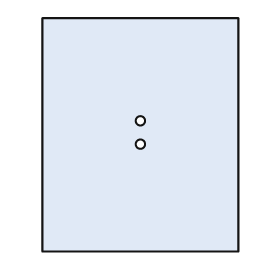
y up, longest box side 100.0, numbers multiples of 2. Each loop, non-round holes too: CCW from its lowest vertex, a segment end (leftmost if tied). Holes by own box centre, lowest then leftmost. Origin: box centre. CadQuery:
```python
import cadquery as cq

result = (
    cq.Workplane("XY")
    .moveTo(-42.0, -50.0)
    .lineTo(42.0, -50.0)
    .lineTo(42.0, 50.0)
    .lineTo(-42.0, 50.0)
    .close()
    .moveTo(0.0, -4.0)
    .circle(2.0)
    .moveTo(0.0, 6.0)
    .circle(2.0)
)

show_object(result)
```